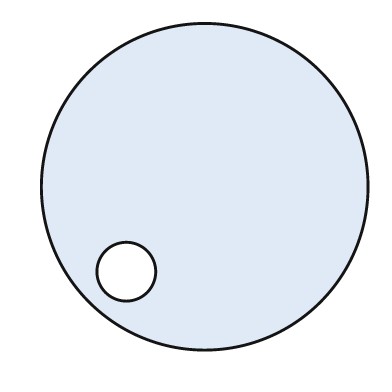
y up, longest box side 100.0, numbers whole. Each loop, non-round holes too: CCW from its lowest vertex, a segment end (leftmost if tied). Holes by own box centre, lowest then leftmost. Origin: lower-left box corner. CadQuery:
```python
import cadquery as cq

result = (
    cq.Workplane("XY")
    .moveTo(50.0, 50.0)
    .circle(50.0)
    .moveTo(26.0, 24.0)
    .circle(9.0)
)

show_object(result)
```